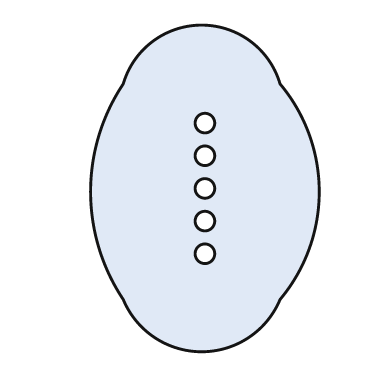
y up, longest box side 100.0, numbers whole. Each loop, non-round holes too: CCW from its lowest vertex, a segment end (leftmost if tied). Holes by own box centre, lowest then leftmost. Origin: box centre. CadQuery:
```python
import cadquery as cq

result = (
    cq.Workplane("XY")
    .moveTo(-25.0, -34.0)
    .threePointArc((-1.0, -50.0), (23.0, -34.0))
    .threePointArc((35.0, -1.0), (23.0, 32.0))
    .threePointArc((-1.0, 50.0), (-25.0, 32.0))
    .threePointArc((-35.0, -1.0), (-25.0, -34.0))
    .close()
    .moveTo(0.0, -20.0)
    .circle(3.0)
    .moveTo(0.0, -10.0)
    .circle(3.0)
    .moveTo(0.0, 0.0)
    .circle(3.0)
    .moveTo(0.0, 10.0)
    .circle(3.0)
    .moveTo(0.0, 20.0)
    .circle(3.0)
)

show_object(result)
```